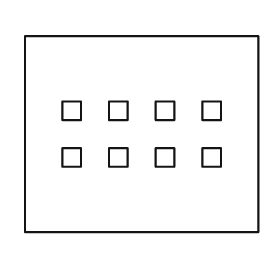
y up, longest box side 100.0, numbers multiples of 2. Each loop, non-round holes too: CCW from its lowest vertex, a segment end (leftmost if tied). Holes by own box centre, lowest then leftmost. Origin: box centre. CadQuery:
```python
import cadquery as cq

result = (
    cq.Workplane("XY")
    .moveTo(-50.0, -42.0)
    .lineTo(50.0, -42.0)
    .lineTo(50.0, 42.0)
    .lineTo(-50.0, 42.0)
    .close()
    .moveTo(-34.0, -14.0)
    .lineTo(-26.0, -14.0)
    .lineTo(-26.0, -6.0)
    .lineTo(-34.0, -6.0)
    .close()
    .moveTo(-14.0, -14.0)
    .lineTo(-6.0, -14.0)
    .lineTo(-6.0, -6.0)
    .lineTo(-14.0, -6.0)
    .close()
    .moveTo(6.0, -14.0)
    .lineTo(14.0, -14.0)
    .lineTo(14.0, -6.0)
    .lineTo(6.0, -6.0)
    .close()
    .moveTo(26.0, -14.0)
    .lineTo(34.0, -14.0)
    .lineTo(34.0, -6.0)
    .lineTo(26.0, -6.0)
    .close()
    .moveTo(-34.0, 6.0)
    .lineTo(-26.0, 6.0)
    .lineTo(-26.0, 14.0)
    .lineTo(-34.0, 14.0)
    .close()
    .moveTo(-14.0, 6.0)
    .lineTo(-6.0, 6.0)
    .lineTo(-6.0, 14.0)
    .lineTo(-14.0, 14.0)
    .close()
    .moveTo(6.0, 6.0)
    .lineTo(14.0, 6.0)
    .lineTo(14.0, 14.0)
    .lineTo(6.0, 14.0)
    .close()
    .moveTo(26.0, 6.0)
    .lineTo(34.0, 6.0)
    .lineTo(34.0, 14.0)
    .lineTo(26.0, 14.0)
    .close()
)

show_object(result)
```